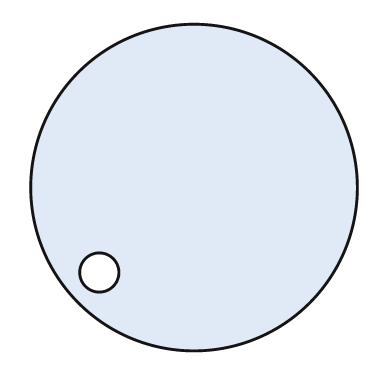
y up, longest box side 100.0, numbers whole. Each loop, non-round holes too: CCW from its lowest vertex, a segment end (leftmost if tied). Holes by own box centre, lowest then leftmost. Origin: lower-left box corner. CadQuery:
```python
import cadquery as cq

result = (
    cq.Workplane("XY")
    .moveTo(50.0, 50.0)
    .circle(50.0)
    .moveTo(21.0, 24.0)
    .circle(6.0)
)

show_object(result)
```